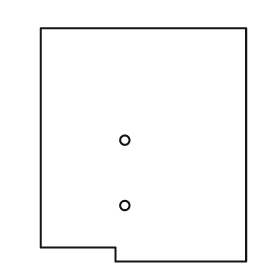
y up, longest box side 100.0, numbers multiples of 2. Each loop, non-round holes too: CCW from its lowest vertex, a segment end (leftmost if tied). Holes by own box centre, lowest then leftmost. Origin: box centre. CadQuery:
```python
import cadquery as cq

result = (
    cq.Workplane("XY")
    .moveTo(-12.0, -50.0)
    .lineTo(44.0, -50.0)
    .lineTo(44.0, 50.0)
    .lineTo(-44.0, 50.0)
    .lineTo(-44.0, -44.0)
    .lineTo(-12.0, -44.0)
    .close()
    .moveTo(-8.0, -26.0)
    .circle(2.0)
    .moveTo(-8.0, 2.0)
    .circle(2.0)
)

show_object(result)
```